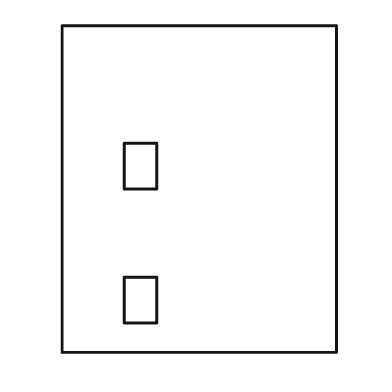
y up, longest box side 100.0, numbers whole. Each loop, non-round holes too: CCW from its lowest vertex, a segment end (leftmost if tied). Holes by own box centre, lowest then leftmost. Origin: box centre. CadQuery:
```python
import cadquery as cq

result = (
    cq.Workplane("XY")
    .moveTo(-42.0, -50.0)
    .lineTo(42.0, -50.0)
    .lineTo(42.0, 50.0)
    .lineTo(-42.0, 50.0)
    .close()
    .moveTo(-23.0, -41.0)
    .lineTo(-13.0, -41.0)
    .lineTo(-13.0, -27.0)
    .lineTo(-23.0, -27.0)
    .close()
    .moveTo(-23.0, 0.0)
    .lineTo(-13.0, 0.0)
    .lineTo(-13.0, 14.0)
    .lineTo(-23.0, 14.0)
    .close()
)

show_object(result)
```